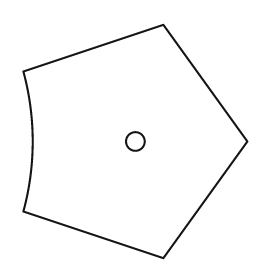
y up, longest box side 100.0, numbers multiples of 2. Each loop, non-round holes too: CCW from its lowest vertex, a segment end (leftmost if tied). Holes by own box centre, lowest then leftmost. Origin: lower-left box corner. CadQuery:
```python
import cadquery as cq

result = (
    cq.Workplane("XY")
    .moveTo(60.0, 0.0)
    .lineTo(96.0, 50.0)
    .lineTo(60.0, 100.0)
    .lineTo(0.0, 80.0)
    .threePointArc((4.0, 50.0), (0.0, 20.0))
    .close()
    .moveTo(48.0, 50.0)
    .circle(4.0)
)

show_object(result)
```